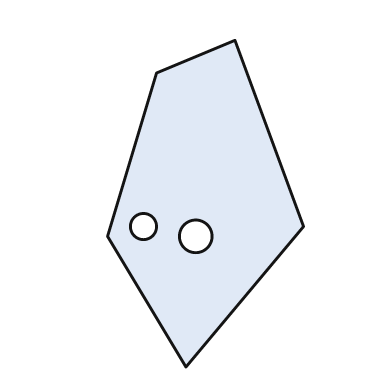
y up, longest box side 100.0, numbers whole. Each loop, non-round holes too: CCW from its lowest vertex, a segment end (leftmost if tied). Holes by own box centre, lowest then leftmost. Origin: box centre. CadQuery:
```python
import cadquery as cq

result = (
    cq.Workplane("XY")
    .moveTo(-6.0, -50.0)
    .lineTo(30.0, -7.0)
    .lineTo(9.0, 50.0)
    .lineTo(-15.0, 40.0)
    .lineTo(-30.0, -10.0)
    .close()
    .moveTo(-3.0, -10.0)
    .circle(5.0)
    .moveTo(-19.0, -7.0)
    .circle(4.0)
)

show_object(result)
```